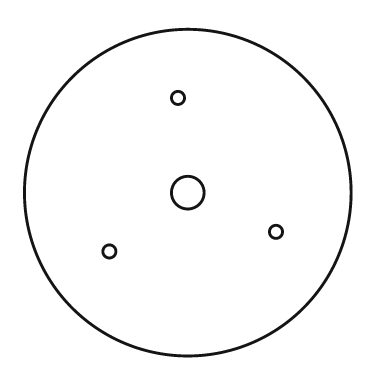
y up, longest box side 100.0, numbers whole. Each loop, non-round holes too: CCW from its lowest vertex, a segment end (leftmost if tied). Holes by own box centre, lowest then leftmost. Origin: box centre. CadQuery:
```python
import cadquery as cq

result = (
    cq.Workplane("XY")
    .moveTo(0.0, 0.0)
    .circle(50.0)
    .moveTo(-24.0, -18.0)
    .circle(2.0)
    .moveTo(27.0, -12.0)
    .circle(2.0)
    .moveTo(0.0, 0.0)
    .circle(5.0)
    .moveTo(-3.0, 29.0)
    .circle(2.0)
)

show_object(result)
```